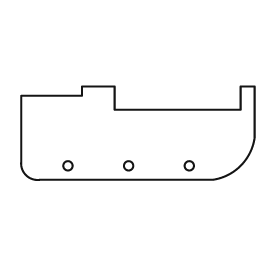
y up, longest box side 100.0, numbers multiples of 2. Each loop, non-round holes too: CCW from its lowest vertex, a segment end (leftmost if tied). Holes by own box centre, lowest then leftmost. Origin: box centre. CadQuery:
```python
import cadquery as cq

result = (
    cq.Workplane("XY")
    .moveTo(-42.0, -20.0)
    .lineTo(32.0, -20.0)
    .threePointArc((44.0, -14.0), (50.0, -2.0))
    .lineTo(50.0, 20.0)
    .lineTo(44.0, 20.0)
    .lineTo(44.0, 10.0)
    .lineTo(-10.0, 10.0)
    .lineTo(-10.0, 20.0)
    .lineTo(-24.0, 20.0)
    .lineTo(-24.0, 16.0)
    .lineTo(-50.0, 16.0)
    .lineTo(-50.0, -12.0)
    .threePointArc((-48.0, -18.0), (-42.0, -20.0))
    .close()
    .moveTo(-30.0, -14.0)
    .circle(2.0)
    .moveTo(-4.0, -14.0)
    .circle(2.0)
    .moveTo(22.0, -14.0)
    .circle(2.0)
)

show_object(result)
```